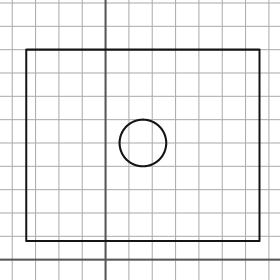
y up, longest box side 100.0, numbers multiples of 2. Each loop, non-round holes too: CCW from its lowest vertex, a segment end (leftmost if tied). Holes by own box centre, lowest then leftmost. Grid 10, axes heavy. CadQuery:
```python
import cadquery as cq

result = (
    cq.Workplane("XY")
    .moveTo(-34.0, 8.0)
    .lineTo(66.0, 8.0)
    .lineTo(66.0, 90.0)
    .lineTo(-34.0, 90.0)
    .close()
    .moveTo(16.0, 50.0)
    .circle(10.0)
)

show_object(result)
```